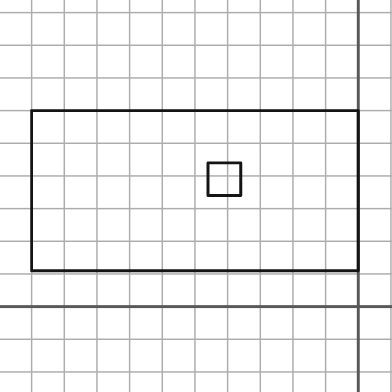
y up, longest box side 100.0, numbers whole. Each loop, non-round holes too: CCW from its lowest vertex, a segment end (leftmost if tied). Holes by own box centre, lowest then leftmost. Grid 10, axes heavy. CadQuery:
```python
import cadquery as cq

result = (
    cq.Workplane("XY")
    .moveTo(-100.0, 11.0)
    .lineTo(0.0, 11.0)
    .lineTo(0.0, 60.0)
    .lineTo(-100.0, 60.0)
    .close()
    .moveTo(-46.0, 34.0)
    .lineTo(-36.0, 34.0)
    .lineTo(-36.0, 44.0)
    .lineTo(-46.0, 44.0)
    .close()
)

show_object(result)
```